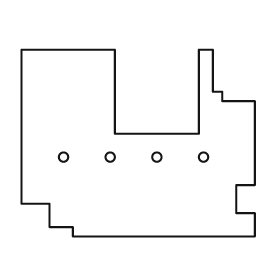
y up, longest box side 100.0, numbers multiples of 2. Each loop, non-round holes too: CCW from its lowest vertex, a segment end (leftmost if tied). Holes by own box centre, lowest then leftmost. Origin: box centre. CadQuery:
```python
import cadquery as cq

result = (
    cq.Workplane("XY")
    .moveTo(-28.0, -40.0)
    .lineTo(50.0, -40.0)
    .lineTo(50.0, -30.0)
    .lineTo(42.0, -30.0)
    .lineTo(42.0, -18.0)
    .lineTo(50.0, -18.0)
    .lineTo(50.0, 18.0)
    .lineTo(36.0, 18.0)
    .lineTo(36.0, 22.0)
    .lineTo(32.0, 22.0)
    .lineTo(32.0, 40.0)
    .lineTo(26.0, 40.0)
    .lineTo(26.0, 4.0)
    .lineTo(-10.0, 4.0)
    .lineTo(-10.0, 40.0)
    .lineTo(-50.0, 40.0)
    .lineTo(-50.0, -26.0)
    .lineTo(-38.0, -26.0)
    .lineTo(-38.0, -36.0)
    .lineTo(-28.0, -36.0)
    .close()
    .moveTo(-32.0, -6.0)
    .circle(2.0)
    .moveTo(-12.0, -6.0)
    .circle(2.0)
    .moveTo(8.0, -6.0)
    .circle(2.0)
    .moveTo(28.0, -6.0)
    .circle(2.0)
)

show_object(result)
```